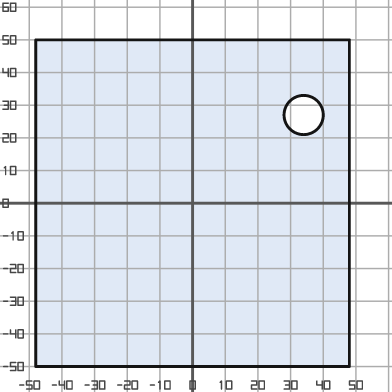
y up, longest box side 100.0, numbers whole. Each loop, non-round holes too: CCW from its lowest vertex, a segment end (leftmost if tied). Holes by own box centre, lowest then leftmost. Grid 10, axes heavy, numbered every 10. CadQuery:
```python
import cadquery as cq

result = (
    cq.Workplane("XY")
    .moveTo(-48.0, -50.0)
    .lineTo(48.0, -50.0)
    .lineTo(48.0, 50.0)
    .lineTo(-48.0, 50.0)
    .close()
    .moveTo(34.0, 27.0)
    .circle(6.0)
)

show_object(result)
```